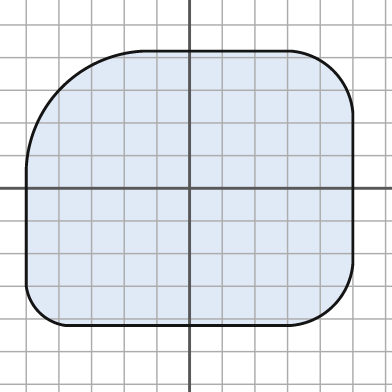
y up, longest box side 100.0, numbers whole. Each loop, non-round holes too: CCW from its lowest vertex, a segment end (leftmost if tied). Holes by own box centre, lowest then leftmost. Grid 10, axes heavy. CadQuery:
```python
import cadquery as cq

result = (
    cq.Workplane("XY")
    .moveTo(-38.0, -42.0)
    .lineTo(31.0, -42.0)
    .threePointArc((44.0, -36.0), (50.0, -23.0))
    .lineTo(50.0, 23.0)
    .threePointArc((44.0, 36.0), (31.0, 42.0))
    .lineTo(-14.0, 42.0)
    .threePointArc((-39.0, 31.0), (-50.0, 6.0))
    .lineTo(-50.0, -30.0)
    .threePointArc((-46.0, -38.0), (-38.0, -42.0))
    .close()
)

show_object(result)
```